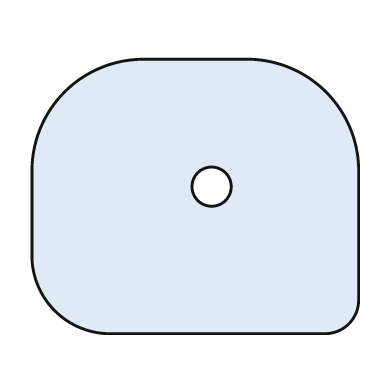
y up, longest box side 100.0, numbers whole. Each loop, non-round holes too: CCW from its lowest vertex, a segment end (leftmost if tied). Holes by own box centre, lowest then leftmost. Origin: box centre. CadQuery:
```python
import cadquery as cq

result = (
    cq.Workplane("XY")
    .moveTo(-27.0, -42.0)
    .lineTo(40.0, -42.0)
    .threePointArc((47.0, -39.0), (50.0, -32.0))
    .lineTo(50.0, 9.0)
    .threePointArc((40.0, 32.0), (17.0, 42.0))
    .lineTo(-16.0, 42.0)
    .threePointArc((-40.0, 32.0), (-50.0, 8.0))
    .lineTo(-50.0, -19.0)
    .threePointArc((-43.0, -35.0), (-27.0, -42.0))
    .close()
    .moveTo(5.0, 3.0)
    .circle(6.0)
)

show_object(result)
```